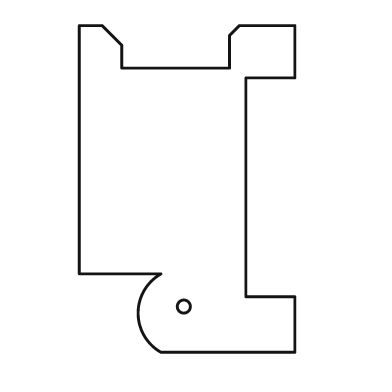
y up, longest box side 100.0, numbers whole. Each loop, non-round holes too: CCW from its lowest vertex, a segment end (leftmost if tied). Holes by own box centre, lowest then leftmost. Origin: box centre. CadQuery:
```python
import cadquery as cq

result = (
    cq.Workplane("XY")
    .moveTo(-8.0, -50.0)
    .lineTo(33.0, -50.0)
    .lineTo(33.0, -33.0)
    .lineTo(18.0, -33.0)
    .lineTo(18.0, 34.0)
    .lineTo(33.0, 34.0)
    .lineTo(33.0, 50.0)
    .lineTo(16.0, 50.0)
    .lineTo(13.0, 47.0)
    .lineTo(13.0, 37.0)
    .lineTo(-20.0, 37.0)
    .lineTo(-20.0, 44.0)
    .lineTo(-26.0, 50.0)
    .lineTo(-33.0, 50.0)
    .lineTo(-33.0, -26.0)
    .lineTo(-8.0, -26.0)
    .threePointArc((-15.0, -38.0), (-8.0, -50.0))
    .close()
    .moveTo(-1.0, -36.0)
    .circle(2.0)
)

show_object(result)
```